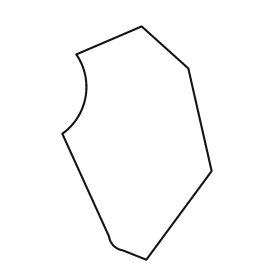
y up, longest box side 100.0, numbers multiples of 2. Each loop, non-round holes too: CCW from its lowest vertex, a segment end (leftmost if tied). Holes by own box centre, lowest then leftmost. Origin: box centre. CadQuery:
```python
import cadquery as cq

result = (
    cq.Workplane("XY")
    .moveTo(4.0, -50.0)
    .lineTo(32.0, -12.0)
    .lineTo(22.0, 32.0)
    .lineTo(2.0, 50.0)
    .lineTo(-26.0, 38.0)
    .threePointArc((-22.0, 20.0), (-32.0, 4.0))
    .lineTo(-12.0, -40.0)
    .threePointArc((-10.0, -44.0), (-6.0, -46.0))
    .close()
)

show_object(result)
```